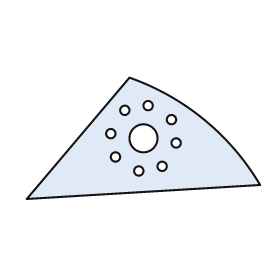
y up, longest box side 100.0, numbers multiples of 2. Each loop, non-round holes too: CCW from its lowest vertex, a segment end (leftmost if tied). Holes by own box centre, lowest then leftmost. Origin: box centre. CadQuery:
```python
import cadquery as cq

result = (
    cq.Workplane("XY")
    .moveTo(-50.0, -26.0)
    .lineTo(50.0, -20.0)
    .threePointArc((26.0, 8.0), (-6.0, 26.0))
    .close()
    .moveTo(-2.0, -14.0)
    .circle(2.0)
    .moveTo(8.0, -12.0)
    .circle(2.0)
    .moveTo(-12.0, -8.0)
    .circle(2.0)
    .moveTo(14.0, -2.0)
    .circle(2.0)
    .moveTo(0.0, 0.0)
    .circle(6.0)
    .moveTo(-14.0, 2.0)
    .circle(2.0)
    .moveTo(12.0, 8.0)
    .circle(2.0)
    .moveTo(-8.0, 12.0)
    .circle(2.0)
    .moveTo(2.0, 14.0)
    .circle(2.0)
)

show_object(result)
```